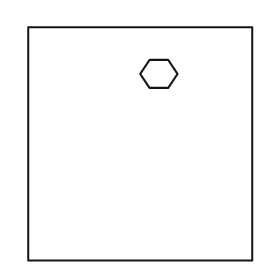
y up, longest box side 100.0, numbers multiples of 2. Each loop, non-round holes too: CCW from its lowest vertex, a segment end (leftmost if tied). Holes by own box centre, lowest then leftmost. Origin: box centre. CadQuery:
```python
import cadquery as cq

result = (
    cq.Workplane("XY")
    .moveTo(-48.0, -50.0)
    .lineTo(48.0, -50.0)
    .lineTo(48.0, 50.0)
    .lineTo(-48.0, 50.0)
    .close()
    .moveTo(4.0, 24.0)
    .lineTo(12.0, 24.0)
    .lineTo(16.0, 30.0)
    .lineTo(12.0, 36.0)
    .lineTo(4.0, 36.0)
    .lineTo(0.0, 30.0)
    .close()
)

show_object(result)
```